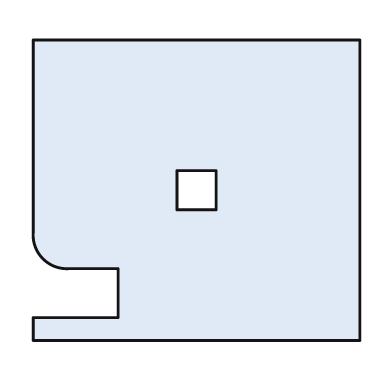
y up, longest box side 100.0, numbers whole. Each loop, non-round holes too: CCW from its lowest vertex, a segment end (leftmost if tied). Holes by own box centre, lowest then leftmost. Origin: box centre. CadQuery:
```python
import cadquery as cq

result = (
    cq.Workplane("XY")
    .moveTo(-50.0, -46.0)
    .lineTo(50.0, -46.0)
    .lineTo(50.0, 46.0)
    .lineTo(-50.0, 46.0)
    .lineTo(-50.0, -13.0)
    .threePointArc((-47.0, -21.0), (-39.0, -24.0))
    .lineTo(-24.0, -24.0)
    .lineTo(-24.0, -39.0)
    .lineTo(-50.0, -39.0)
    .close()
    .moveTo(-6.0, -6.0)
    .lineTo(6.0, -6.0)
    .lineTo(6.0, 6.0)
    .lineTo(-6.0, 6.0)
    .close()
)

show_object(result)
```